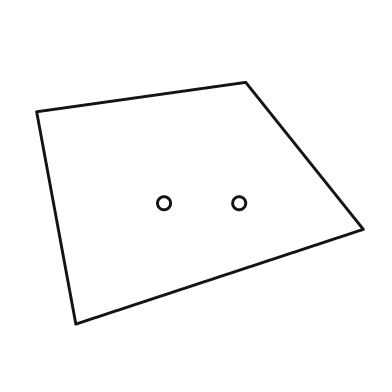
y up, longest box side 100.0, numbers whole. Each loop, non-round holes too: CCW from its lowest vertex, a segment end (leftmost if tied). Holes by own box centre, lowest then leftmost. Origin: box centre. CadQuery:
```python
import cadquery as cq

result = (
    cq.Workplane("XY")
    .moveTo(-38.0, -37.0)
    .lineTo(50.0, -8.0)
    .lineTo(14.0, 37.0)
    .lineTo(-50.0, 28.0)
    .close()
    .moveTo(-11.0, 0.0)
    .circle(2.0)
    .moveTo(12.0, 0.0)
    .circle(2.0)
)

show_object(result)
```